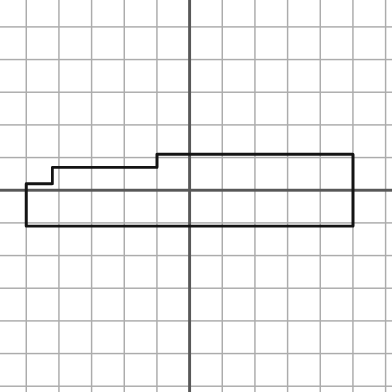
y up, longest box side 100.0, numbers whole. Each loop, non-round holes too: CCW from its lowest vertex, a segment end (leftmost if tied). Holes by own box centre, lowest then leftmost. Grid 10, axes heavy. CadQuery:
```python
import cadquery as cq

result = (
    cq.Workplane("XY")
    .moveTo(-50.0, -11.0)
    .lineTo(50.0, -11.0)
    .lineTo(50.0, 11.0)
    .lineTo(-10.0, 11.0)
    .lineTo(-10.0, 7.0)
    .lineTo(-42.0, 7.0)
    .lineTo(-42.0, 2.0)
    .lineTo(-50.0, 2.0)
    .close()
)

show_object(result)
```